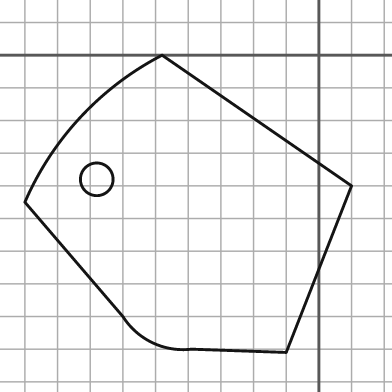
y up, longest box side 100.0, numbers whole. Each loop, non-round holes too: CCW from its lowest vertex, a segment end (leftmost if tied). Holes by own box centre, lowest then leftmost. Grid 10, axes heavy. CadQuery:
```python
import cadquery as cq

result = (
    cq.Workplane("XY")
    .moveTo(-10.0, -91.0)
    .lineTo(10.0, -40.0)
    .lineTo(-48.0, 0.0)
    .threePointArc((-73.0, -19.0), (-90.0, -45.0))
    .lineTo(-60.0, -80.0)
    .threePointArc((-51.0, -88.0), (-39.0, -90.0))
    .close()
    .moveTo(-68.0, -38.0)
    .circle(5.0)
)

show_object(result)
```